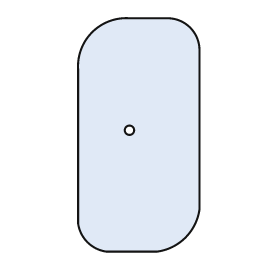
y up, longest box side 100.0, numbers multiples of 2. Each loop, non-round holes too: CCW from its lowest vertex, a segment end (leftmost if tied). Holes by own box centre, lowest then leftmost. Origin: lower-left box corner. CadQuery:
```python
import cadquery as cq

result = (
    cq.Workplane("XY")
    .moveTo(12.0, 0.0)
    .lineTo(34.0, 0.0)
    .threePointArc((46.0, 6.0), (52.0, 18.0))
    .lineTo(52.0, 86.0)
    .threePointArc((48.0, 96.0), (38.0, 100.0))
    .lineTo(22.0, 100.0)
    .threePointArc((6.0, 94.0), (0.0, 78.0))
    .lineTo(0.0, 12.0)
    .threePointArc((4.0, 4.0), (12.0, 0.0))
    .close()
    .moveTo(22.0, 52.0)
    .circle(2.0)
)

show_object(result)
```